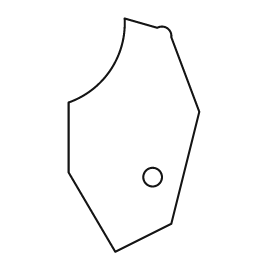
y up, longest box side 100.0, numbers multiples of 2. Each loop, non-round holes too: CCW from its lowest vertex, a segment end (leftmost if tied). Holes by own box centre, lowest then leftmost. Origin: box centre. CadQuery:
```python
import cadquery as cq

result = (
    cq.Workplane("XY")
    .moveTo(-8.0, -50.0)
    .lineTo(16.0, -38.0)
    .lineTo(28.0, 10.0)
    .lineTo(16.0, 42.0)
    .threePointArc((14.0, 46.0), (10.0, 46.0))
    .lineTo(-4.0, 50.0)
    .threePointArc((-10.0, 28.0), (-28.0, 14.0))
    .lineTo(-28.0, -16.0)
    .close()
    .moveTo(8.0, -18.0)
    .circle(4.0)
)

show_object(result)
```